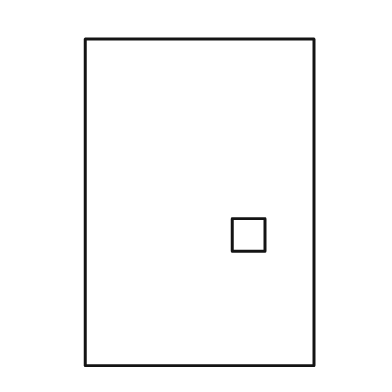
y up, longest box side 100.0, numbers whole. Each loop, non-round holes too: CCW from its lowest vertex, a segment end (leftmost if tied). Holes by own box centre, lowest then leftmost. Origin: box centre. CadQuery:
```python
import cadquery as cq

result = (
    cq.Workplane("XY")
    .moveTo(-35.0, -50.0)
    .lineTo(35.0, -50.0)
    .lineTo(35.0, 50.0)
    .lineTo(-35.0, 50.0)
    .close()
    .moveTo(10.0, -15.0)
    .lineTo(20.0, -15.0)
    .lineTo(20.0, -5.0)
    .lineTo(10.0, -5.0)
    .close()
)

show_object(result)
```